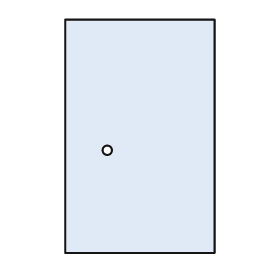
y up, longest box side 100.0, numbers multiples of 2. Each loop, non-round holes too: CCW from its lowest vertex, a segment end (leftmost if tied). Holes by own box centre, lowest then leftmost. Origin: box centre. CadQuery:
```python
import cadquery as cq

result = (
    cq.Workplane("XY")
    .moveTo(-32.0, -50.0)
    .lineTo(32.0, -50.0)
    .lineTo(32.0, 50.0)
    .lineTo(-32.0, 50.0)
    .close()
    .moveTo(-14.0, -6.0)
    .circle(2.0)
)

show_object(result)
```